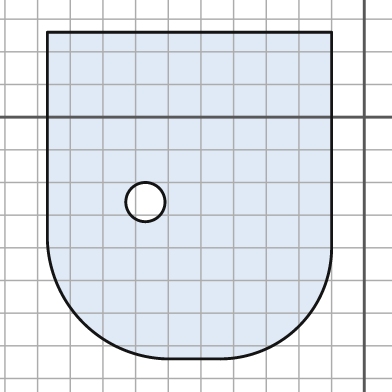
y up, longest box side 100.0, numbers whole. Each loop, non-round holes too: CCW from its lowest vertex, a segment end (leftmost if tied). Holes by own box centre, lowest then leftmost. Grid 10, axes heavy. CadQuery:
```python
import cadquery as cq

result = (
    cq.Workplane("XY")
    .moveTo(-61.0, -74.0)
    .lineTo(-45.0, -74.0)
    .threePointArc((-20.0, -64.0), (-10.0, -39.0))
    .lineTo(-10.0, 26.0)
    .lineTo(-97.0, 26.0)
    .lineTo(-97.0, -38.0)
    .threePointArc((-86.0, -63.0), (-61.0, -74.0))
    .close()
    .moveTo(-67.0, -26.0)
    .circle(6.0)
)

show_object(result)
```